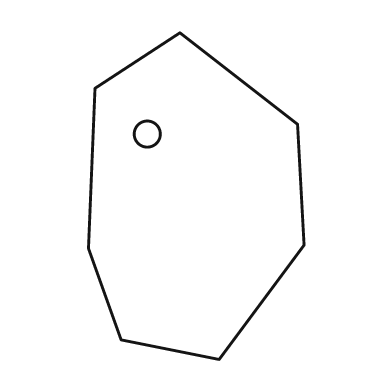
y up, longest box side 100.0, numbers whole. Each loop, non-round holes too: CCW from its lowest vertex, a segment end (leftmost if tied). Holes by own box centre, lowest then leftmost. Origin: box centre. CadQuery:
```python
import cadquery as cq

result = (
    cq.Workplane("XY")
    .moveTo(7.0, -50.0)
    .lineTo(33.0, -15.0)
    .lineTo(31.0, 22.0)
    .lineTo(-5.0, 50.0)
    .lineTo(-31.0, 33.0)
    .lineTo(-33.0, -16.0)
    .lineTo(-23.0, -44.0)
    .close()
    .moveTo(-15.0, 19.0)
    .circle(4.0)
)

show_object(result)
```